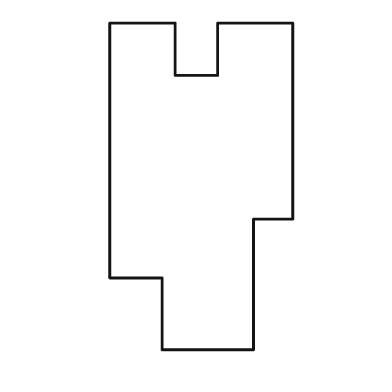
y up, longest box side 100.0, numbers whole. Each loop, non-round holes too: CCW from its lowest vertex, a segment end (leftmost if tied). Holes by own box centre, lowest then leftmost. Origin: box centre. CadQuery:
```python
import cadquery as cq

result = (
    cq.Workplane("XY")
    .moveTo(-12.0, -50.0)
    .lineTo(16.0, -50.0)
    .lineTo(16.0, -10.0)
    .lineTo(28.0, -10.0)
    .lineTo(28.0, 50.0)
    .lineTo(5.0, 50.0)
    .lineTo(5.0, 34.0)
    .lineTo(-8.0, 34.0)
    .lineTo(-8.0, 50.0)
    .lineTo(-28.0, 50.0)
    .lineTo(-28.0, -28.0)
    .lineTo(-12.0, -28.0)
    .close()
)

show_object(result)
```